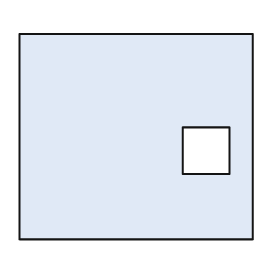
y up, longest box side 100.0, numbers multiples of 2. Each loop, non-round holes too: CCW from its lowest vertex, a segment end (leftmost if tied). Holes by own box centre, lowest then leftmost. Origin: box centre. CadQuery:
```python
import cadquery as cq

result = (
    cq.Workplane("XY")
    .moveTo(-50.0, -44.0)
    .lineTo(50.0, -44.0)
    .lineTo(50.0, 44.0)
    .lineTo(-50.0, 44.0)
    .close()
    .moveTo(20.0, -16.0)
    .lineTo(40.0, -16.0)
    .lineTo(40.0, 4.0)
    .lineTo(20.0, 4.0)
    .close()
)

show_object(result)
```